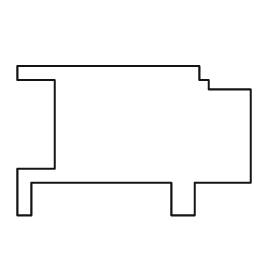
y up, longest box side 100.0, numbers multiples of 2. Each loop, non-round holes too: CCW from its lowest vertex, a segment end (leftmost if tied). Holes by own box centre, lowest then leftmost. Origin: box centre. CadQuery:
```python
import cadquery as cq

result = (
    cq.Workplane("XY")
    .moveTo(-50.0, -32.0)
    .lineTo(-44.0, -32.0)
    .lineTo(-44.0, -18.0)
    .lineTo(16.0, -18.0)
    .lineTo(16.0, -32.0)
    .lineTo(26.0, -32.0)
    .lineTo(26.0, -18.0)
    .lineTo(50.0, -18.0)
    .lineTo(50.0, 22.0)
    .lineTo(32.0, 22.0)
    .lineTo(32.0, 26.0)
    .lineTo(28.0, 26.0)
    .lineTo(28.0, 32.0)
    .lineTo(-50.0, 32.0)
    .lineTo(-50.0, 26.0)
    .lineTo(-34.0, 26.0)
    .lineTo(-34.0, -12.0)
    .lineTo(-50.0, -12.0)
    .close()
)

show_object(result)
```